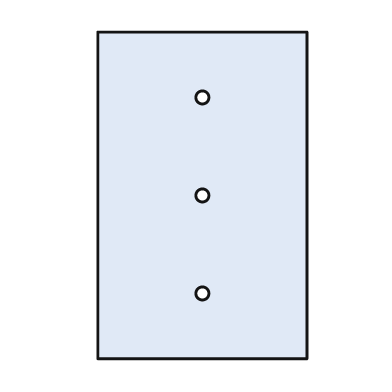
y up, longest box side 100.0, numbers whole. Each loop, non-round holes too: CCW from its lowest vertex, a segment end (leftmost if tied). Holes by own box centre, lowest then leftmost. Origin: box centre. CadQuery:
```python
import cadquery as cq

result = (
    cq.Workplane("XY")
    .moveTo(-32.0, -50.0)
    .lineTo(32.0, -50.0)
    .lineTo(32.0, 50.0)
    .lineTo(-32.0, 50.0)
    .close()
    .moveTo(0.0, -30.0)
    .circle(2.0)
    .moveTo(0.0, 0.0)
    .circle(2.0)
    .moveTo(0.0, 30.0)
    .circle(2.0)
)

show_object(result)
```